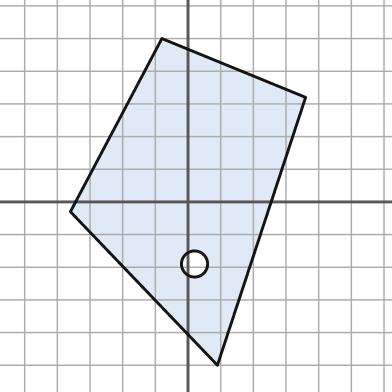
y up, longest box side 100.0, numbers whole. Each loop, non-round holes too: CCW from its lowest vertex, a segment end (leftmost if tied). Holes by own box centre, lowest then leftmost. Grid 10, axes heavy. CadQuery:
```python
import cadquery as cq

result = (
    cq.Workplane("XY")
    .moveTo(9.0, -50.0)
    .lineTo(36.0, 32.0)
    .lineTo(-8.0, 50.0)
    .lineTo(-36.0, -3.0)
    .close()
    .moveTo(2.0, -19.0)
    .circle(4.0)
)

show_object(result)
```